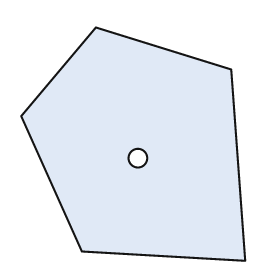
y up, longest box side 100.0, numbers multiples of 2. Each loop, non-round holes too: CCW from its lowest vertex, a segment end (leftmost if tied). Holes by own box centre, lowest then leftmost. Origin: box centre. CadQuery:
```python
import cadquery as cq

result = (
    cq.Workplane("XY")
    .moveTo(48.0, -50.0)
    .lineTo(42.0, 32.0)
    .lineTo(-16.0, 50.0)
    .lineTo(-48.0, 12.0)
    .lineTo(-22.0, -46.0)
    .close()
    .moveTo(2.0, -6.0)
    .circle(4.0)
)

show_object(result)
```